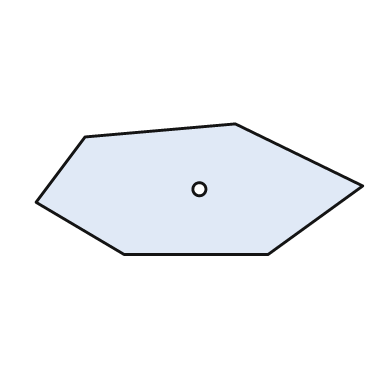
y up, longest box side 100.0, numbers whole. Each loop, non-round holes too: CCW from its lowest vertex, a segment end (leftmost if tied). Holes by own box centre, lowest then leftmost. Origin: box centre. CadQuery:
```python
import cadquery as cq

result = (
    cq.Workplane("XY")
    .moveTo(-23.0, -20.0)
    .lineTo(21.0, -20.0)
    .lineTo(50.0, 1.0)
    .lineTo(11.0, 20.0)
    .lineTo(-35.0, 16.0)
    .lineTo(-50.0, -4.0)
    .close()
    .moveTo(0.0, 0.0)
    .circle(2.0)
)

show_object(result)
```